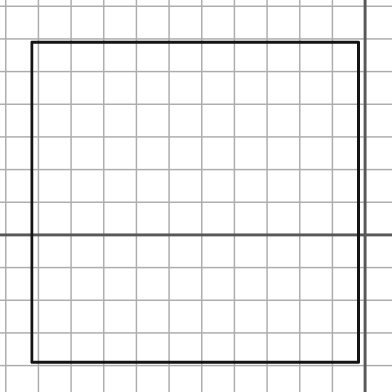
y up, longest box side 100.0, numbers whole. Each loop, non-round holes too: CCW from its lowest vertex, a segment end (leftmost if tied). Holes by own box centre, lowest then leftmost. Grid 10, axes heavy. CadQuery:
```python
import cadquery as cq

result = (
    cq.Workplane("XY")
    .moveTo(-102.0, -39.0)
    .lineTo(-2.0, -39.0)
    .lineTo(-2.0, 59.0)
    .lineTo(-102.0, 59.0)
    .close()
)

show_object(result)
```